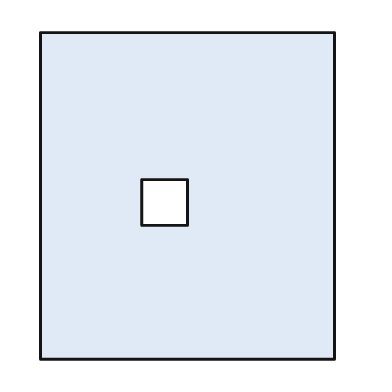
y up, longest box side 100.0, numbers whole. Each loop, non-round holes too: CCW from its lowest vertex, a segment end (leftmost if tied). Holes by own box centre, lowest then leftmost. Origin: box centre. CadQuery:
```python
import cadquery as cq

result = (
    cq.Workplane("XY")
    .moveTo(-45.0, -50.0)
    .lineTo(45.0, -50.0)
    .lineTo(45.0, 50.0)
    .lineTo(-45.0, 50.0)
    .close()
    .moveTo(-14.0, -9.0)
    .lineTo(0.0, -9.0)
    .lineTo(0.0, 5.0)
    .lineTo(-14.0, 5.0)
    .close()
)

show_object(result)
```